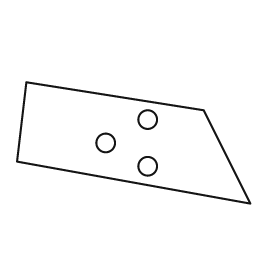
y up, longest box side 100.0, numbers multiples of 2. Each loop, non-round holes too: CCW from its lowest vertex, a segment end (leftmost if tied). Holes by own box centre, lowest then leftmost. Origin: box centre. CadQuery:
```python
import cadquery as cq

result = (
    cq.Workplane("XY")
    .moveTo(50.0, -26.0)
    .lineTo(30.0, 14.0)
    .lineTo(-46.0, 26.0)
    .lineTo(-50.0, -8.0)
    .close()
    .moveTo(6.0, -10.0)
    .circle(4.0)
    .moveTo(-12.0, 0.0)
    .circle(4.0)
    .moveTo(6.0, 10.0)
    .circle(4.0)
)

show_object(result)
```